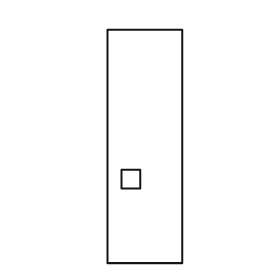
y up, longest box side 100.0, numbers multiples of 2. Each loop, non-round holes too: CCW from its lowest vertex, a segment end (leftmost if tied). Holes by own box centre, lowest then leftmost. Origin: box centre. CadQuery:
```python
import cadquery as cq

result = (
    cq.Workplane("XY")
    .moveTo(-16.0, -50.0)
    .lineTo(16.0, -50.0)
    .lineTo(16.0, 50.0)
    .lineTo(-16.0, 50.0)
    .close()
    .moveTo(-10.0, -18.0)
    .lineTo(-2.0, -18.0)
    .lineTo(-2.0, -10.0)
    .lineTo(-10.0, -10.0)
    .close()
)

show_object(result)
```